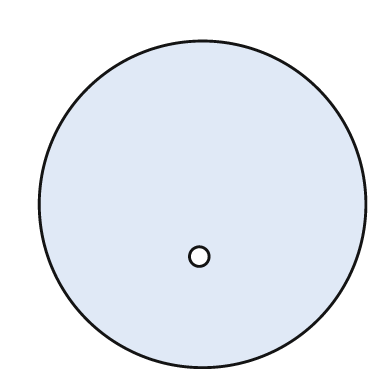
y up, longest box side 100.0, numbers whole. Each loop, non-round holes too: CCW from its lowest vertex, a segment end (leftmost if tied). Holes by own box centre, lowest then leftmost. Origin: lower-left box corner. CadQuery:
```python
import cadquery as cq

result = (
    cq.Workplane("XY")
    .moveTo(50.0, 50.0)
    .circle(50.0)
    .moveTo(49.0, 34.0)
    .circle(3.0)
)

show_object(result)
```